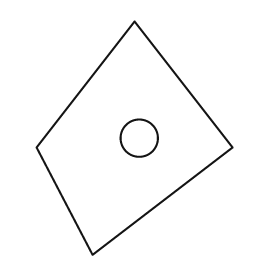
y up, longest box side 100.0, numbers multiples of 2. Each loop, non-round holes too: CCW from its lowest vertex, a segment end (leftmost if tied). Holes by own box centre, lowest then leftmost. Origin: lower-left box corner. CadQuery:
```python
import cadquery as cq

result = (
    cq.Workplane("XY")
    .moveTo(24.0, 0.0)
    .lineTo(84.0, 46.0)
    .lineTo(42.0, 100.0)
    .lineTo(0.0, 46.0)
    .close()
    .moveTo(44.0, 50.0)
    .circle(8.0)
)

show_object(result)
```